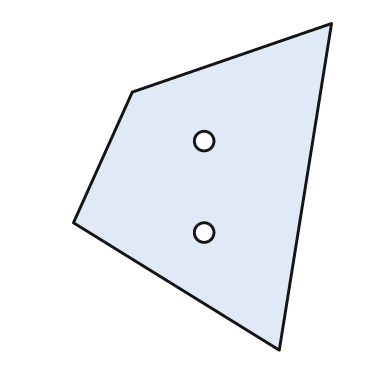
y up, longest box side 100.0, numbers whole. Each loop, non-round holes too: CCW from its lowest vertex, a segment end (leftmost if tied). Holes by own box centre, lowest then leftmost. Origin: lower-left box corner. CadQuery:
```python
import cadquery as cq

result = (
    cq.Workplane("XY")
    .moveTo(63.0, 0.0)
    .lineTo(79.0, 100.0)
    .lineTo(18.0, 79.0)
    .lineTo(0.0, 39.0)
    .close()
    .moveTo(40.0, 36.0)
    .circle(3.0)
    .moveTo(40.0, 64.0)
    .circle(3.0)
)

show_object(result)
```